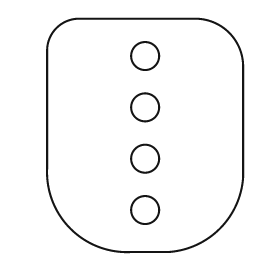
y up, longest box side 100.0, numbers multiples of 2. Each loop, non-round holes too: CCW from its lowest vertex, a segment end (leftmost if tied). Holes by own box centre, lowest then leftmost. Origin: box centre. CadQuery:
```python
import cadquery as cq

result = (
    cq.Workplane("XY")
    .moveTo(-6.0, -50.0)
    .lineTo(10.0, -50.0)
    .threePointArc((32.0, -40.0), (42.0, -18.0))
    .lineTo(42.0, 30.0)
    .threePointArc((36.0, 44.0), (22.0, 50.0))
    .lineTo(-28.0, 50.0)
    .threePointArc((-38.0, 46.0), (-42.0, 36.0))
    .lineTo(-42.0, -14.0)
    .threePointArc((-32.0, -40.0), (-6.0, -50.0))
    .close()
    .moveTo(0.0, -32.0)
    .circle(6.0)
    .moveTo(0.0, -10.0)
    .circle(6.0)
    .moveTo(0.0, 12.0)
    .circle(6.0)
    .moveTo(0.0, 34.0)
    .circle(6.0)
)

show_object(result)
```